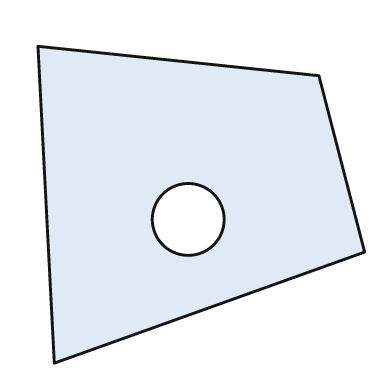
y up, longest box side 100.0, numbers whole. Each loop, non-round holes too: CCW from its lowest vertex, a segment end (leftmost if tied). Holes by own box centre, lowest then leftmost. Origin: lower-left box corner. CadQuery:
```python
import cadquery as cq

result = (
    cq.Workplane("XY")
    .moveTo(5.0, 0.0)
    .lineTo(100.0, 34.0)
    .lineTo(86.0, 88.0)
    .lineTo(0.0, 97.0)
    .close()
    .moveTo(46.0, 44.0)
    .circle(11.0)
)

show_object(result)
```